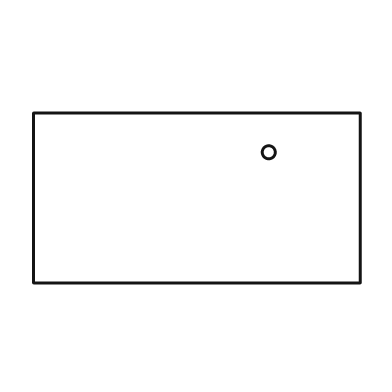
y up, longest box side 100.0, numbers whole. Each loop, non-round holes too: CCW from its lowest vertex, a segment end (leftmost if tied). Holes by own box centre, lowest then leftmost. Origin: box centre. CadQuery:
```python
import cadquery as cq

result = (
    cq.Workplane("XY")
    .moveTo(-50.0, -26.0)
    .lineTo(50.0, -26.0)
    .lineTo(50.0, 26.0)
    .lineTo(-50.0, 26.0)
    .close()
    .moveTo(22.0, 14.0)
    .circle(2.0)
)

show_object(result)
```